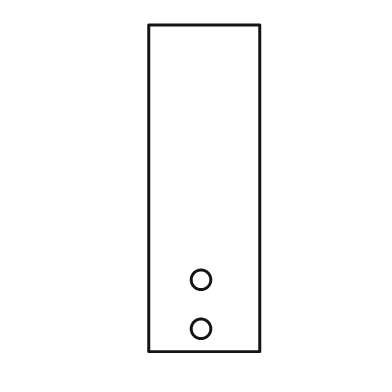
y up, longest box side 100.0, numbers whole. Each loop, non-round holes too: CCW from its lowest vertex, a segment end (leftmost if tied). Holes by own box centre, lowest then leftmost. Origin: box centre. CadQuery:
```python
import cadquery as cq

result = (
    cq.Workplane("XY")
    .moveTo(-17.0, -50.0)
    .lineTo(17.0, -50.0)
    .lineTo(17.0, 50.0)
    .lineTo(-17.0, 50.0)
    .close()
    .moveTo(-1.0, -43.0)
    .circle(3.0)
    .moveTo(-1.0, -28.0)
    .circle(3.0)
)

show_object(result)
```